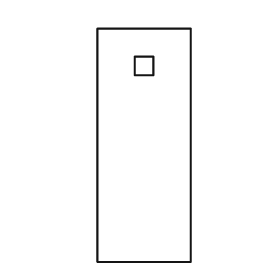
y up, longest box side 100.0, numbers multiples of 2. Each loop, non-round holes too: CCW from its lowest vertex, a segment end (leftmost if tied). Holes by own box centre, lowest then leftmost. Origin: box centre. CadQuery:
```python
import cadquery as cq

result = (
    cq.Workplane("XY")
    .moveTo(-20.0, -50.0)
    .lineTo(20.0, -50.0)
    .lineTo(20.0, 50.0)
    .lineTo(-20.0, 50.0)
    .close()
    .moveTo(-4.0, 30.0)
    .lineTo(4.0, 30.0)
    .lineTo(4.0, 38.0)
    .lineTo(-4.0, 38.0)
    .close()
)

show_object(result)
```